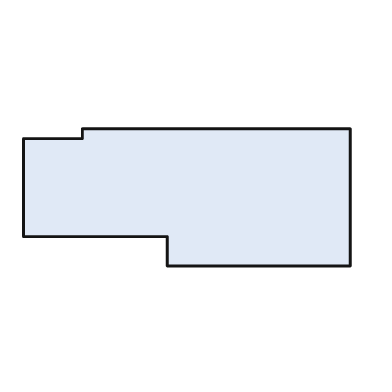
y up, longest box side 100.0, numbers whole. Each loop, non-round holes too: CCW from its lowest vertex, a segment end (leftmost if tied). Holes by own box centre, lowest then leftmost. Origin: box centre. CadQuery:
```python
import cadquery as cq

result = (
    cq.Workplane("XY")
    .moveTo(-6.0, -21.0)
    .lineTo(50.0, -21.0)
    .lineTo(50.0, 21.0)
    .lineTo(-32.0, 21.0)
    .lineTo(-32.0, 18.0)
    .lineTo(-50.0, 18.0)
    .lineTo(-50.0, -12.0)
    .lineTo(-6.0, -12.0)
    .close()
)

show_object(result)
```